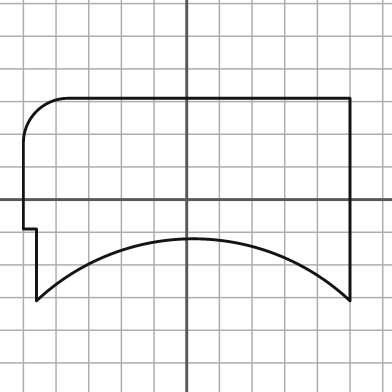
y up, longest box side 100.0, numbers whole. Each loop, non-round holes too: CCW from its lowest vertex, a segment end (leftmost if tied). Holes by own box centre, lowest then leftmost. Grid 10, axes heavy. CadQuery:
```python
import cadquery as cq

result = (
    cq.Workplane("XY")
    .moveTo(-46.0, -31.0)
    .threePointArc((2.0, -12.0), (50.0, -31.0))
    .lineTo(50.0, 31.0)
    .lineTo(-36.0, 31.0)
    .threePointArc((-46.0, 27.0), (-50.0, 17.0))
    .lineTo(-50.0, -9.0)
    .lineTo(-46.0, -9.0)
    .close()
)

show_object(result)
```